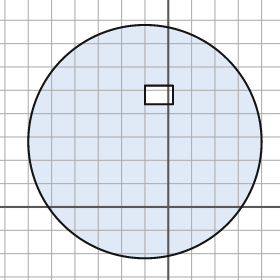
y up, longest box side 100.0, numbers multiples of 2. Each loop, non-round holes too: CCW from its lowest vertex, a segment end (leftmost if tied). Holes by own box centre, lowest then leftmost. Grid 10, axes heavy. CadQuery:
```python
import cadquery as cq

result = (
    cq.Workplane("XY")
    .moveTo(-10.0, 28.0)
    .circle(50.0)
    .moveTo(-10.0, 44.0)
    .lineTo(2.0, 44.0)
    .lineTo(2.0, 52.0)
    .lineTo(-10.0, 52.0)
    .close()
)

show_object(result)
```